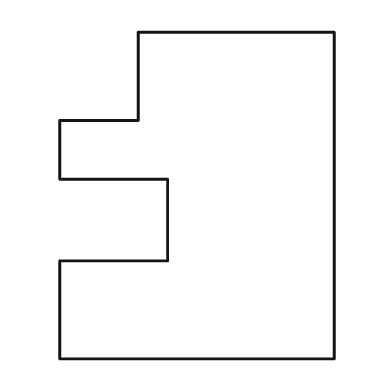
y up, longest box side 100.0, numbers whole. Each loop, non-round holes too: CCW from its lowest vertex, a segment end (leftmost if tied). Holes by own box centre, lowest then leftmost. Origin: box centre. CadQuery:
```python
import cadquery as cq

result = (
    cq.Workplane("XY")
    .moveTo(-42.0, -50.0)
    .lineTo(42.0, -50.0)
    .lineTo(42.0, 50.0)
    .lineTo(-18.0, 50.0)
    .lineTo(-18.0, 23.0)
    .lineTo(-42.0, 23.0)
    .lineTo(-42.0, 5.0)
    .lineTo(-9.0, 5.0)
    .lineTo(-9.0, -20.0)
    .lineTo(-42.0, -20.0)
    .close()
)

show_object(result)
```